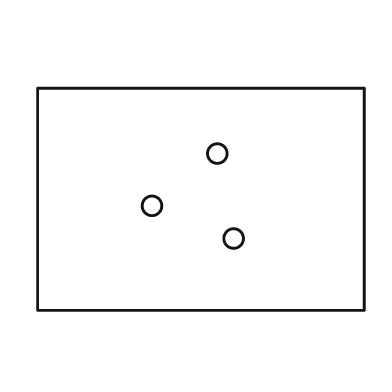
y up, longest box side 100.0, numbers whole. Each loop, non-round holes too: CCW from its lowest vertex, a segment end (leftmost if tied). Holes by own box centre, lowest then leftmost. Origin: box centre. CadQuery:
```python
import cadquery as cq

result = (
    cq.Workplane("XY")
    .moveTo(-50.0, -34.0)
    .lineTo(50.0, -34.0)
    .lineTo(50.0, 34.0)
    .lineTo(-50.0, 34.0)
    .close()
    .moveTo(10.0, -12.0)
    .circle(3.0)
    .moveTo(-15.0, -2.0)
    .circle(3.0)
    .moveTo(5.0, 14.0)
    .circle(3.0)
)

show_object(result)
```